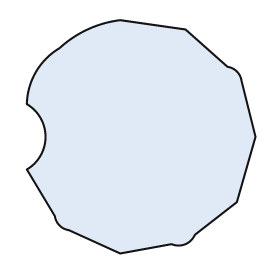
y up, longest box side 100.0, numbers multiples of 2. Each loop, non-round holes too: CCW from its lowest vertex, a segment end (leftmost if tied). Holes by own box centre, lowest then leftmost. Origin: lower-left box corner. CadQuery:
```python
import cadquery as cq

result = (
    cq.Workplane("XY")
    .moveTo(40.0, 0.0)
    .lineTo(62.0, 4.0)
    .threePointArc((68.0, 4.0), (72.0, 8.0))
    .lineTo(90.0, 22.0)
    .lineTo(98.0, 50.0)
    .lineTo(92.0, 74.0)
    .threePointArc((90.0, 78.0), (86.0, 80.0))
    .lineTo(68.0, 96.0)
    .lineTo(40.0, 100.0)
    .threePointArc((26.0, 96.0), (14.0, 88.0))
    .threePointArc((4.0, 78.0), (0.0, 64.0))
    .threePointArc((8.0, 50.0), (0.0, 36.0))
    .lineTo(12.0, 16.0)
    .threePointArc((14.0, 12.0), (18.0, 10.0))
    .close()
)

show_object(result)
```